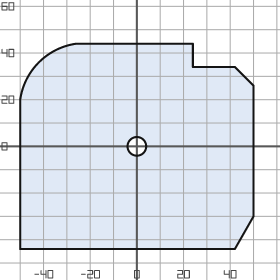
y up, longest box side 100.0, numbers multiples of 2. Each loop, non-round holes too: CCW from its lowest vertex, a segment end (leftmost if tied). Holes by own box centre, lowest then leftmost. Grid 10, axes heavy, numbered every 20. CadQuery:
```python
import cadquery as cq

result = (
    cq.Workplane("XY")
    .moveTo(-50.0, -44.0)
    .lineTo(42.0, -44.0)
    .lineTo(50.0, -30.0)
    .lineTo(50.0, 26.0)
    .lineTo(42.0, 34.0)
    .lineTo(24.0, 34.0)
    .lineTo(24.0, 44.0)
    .lineTo(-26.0, 44.0)
    .threePointArc((-42.0, 36.0), (-50.0, 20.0))
    .close()
    .moveTo(0.0, 0.0)
    .circle(4.0)
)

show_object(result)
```